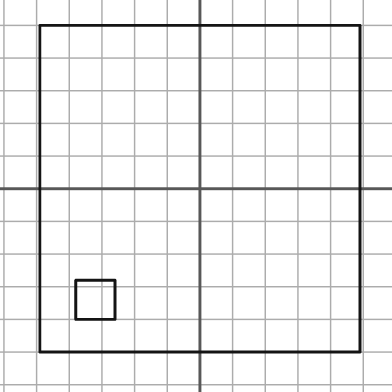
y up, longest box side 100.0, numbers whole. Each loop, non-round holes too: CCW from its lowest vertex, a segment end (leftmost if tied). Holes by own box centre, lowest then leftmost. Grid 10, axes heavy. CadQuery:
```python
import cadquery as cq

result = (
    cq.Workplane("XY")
    .moveTo(-49.0, -50.0)
    .lineTo(49.0, -50.0)
    .lineTo(49.0, 50.0)
    .lineTo(-49.0, 50.0)
    .close()
    .moveTo(-38.0, -40.0)
    .lineTo(-26.0, -40.0)
    .lineTo(-26.0, -28.0)
    .lineTo(-38.0, -28.0)
    .close()
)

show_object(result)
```